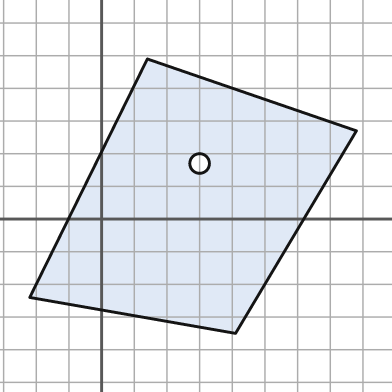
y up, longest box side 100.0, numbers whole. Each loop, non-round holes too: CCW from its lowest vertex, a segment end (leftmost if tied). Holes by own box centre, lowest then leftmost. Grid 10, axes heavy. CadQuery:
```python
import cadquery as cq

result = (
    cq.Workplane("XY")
    .moveTo(41.0, -35.0)
    .lineTo(78.0, 27.0)
    .lineTo(14.0, 49.0)
    .lineTo(-22.0, -24.0)
    .close()
    .moveTo(30.0, 17.0)
    .circle(3.0)
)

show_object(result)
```